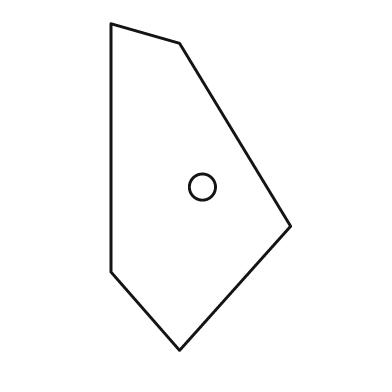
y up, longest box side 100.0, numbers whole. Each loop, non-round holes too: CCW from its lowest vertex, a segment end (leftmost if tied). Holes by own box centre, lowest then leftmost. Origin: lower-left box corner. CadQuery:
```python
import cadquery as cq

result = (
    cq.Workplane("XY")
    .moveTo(21.0, 0.0)
    .lineTo(55.0, 38.0)
    .lineTo(21.0, 94.0)
    .lineTo(0.0, 100.0)
    .lineTo(0.0, 24.0)
    .close()
    .moveTo(28.0, 50.0)
    .circle(4.0)
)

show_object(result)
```